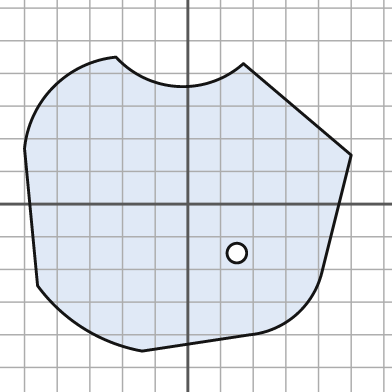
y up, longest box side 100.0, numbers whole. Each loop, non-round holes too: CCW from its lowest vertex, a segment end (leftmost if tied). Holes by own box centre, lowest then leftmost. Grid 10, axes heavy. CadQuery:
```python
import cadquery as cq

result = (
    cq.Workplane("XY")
    .moveTo(-14.0, -45.0)
    .lineTo(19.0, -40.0)
    .threePointArc((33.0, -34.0), (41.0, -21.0))
    .lineTo(50.0, 15.0)
    .lineTo(17.0, 43.0)
    .threePointArc((-3.0, 36.0), (-22.0, 45.0))
    .threePointArc((-41.0, 36.0), (-50.0, 17.0))
    .lineTo(-46.0, -25.0)
    .threePointArc((-32.0, -38.0), (-14.0, -45.0))
    .close()
    .moveTo(15.0, -15.0)
    .circle(3.0)
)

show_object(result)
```